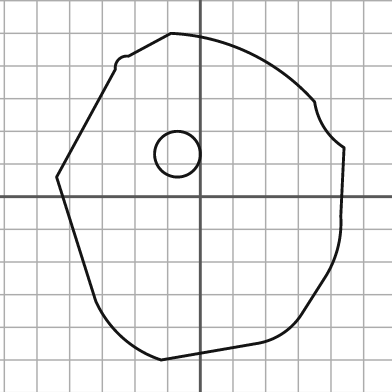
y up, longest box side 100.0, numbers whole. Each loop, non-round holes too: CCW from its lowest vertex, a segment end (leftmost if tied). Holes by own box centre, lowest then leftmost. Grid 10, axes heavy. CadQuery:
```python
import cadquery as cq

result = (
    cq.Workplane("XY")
    .moveTo(-12.0, -50.0)
    .lineTo(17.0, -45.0)
    .threePointArc((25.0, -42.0), (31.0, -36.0))
    .lineTo(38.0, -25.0)
    .threePointArc((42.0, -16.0), (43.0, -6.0))
    .lineTo(44.0, 15.0)
    .threePointArc((38.0, 21.0), (35.0, 29.0))
    .threePointArc((15.0, 44.0), (-9.0, 50.0))
    .lineTo(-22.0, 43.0)
    .threePointArc((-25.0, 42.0), (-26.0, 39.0))
    .lineTo(-44.0, 6.0)
    .lineTo(-32.0, -32.0)
    .threePointArc((-24.0, -43.0), (-12.0, -50.0))
    .close()
    .moveTo(-7.0, 13.0)
    .circle(7.0)
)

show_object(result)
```